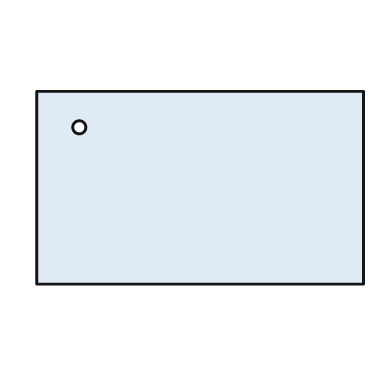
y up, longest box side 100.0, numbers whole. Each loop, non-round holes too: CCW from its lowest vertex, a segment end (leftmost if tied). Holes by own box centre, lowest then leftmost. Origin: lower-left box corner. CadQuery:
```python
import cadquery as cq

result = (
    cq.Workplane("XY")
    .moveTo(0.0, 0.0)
    .lineTo(100.0, 0.0)
    .lineTo(100.0, 59.0)
    .lineTo(0.0, 59.0)
    .close()
    .moveTo(13.0, 48.0)
    .circle(2.0)
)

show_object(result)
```